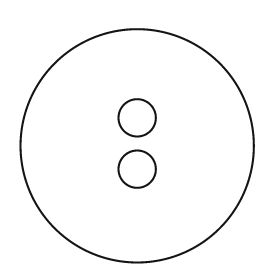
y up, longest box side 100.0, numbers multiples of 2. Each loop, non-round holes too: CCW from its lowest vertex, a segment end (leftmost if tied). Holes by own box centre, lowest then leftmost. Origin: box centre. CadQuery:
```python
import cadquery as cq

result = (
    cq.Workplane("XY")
    .moveTo(0.0, 0.0)
    .circle(50.0)
    .moveTo(0.0, -10.0)
    .circle(8.0)
    .moveTo(0.0, 12.0)
    .circle(8.0)
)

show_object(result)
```